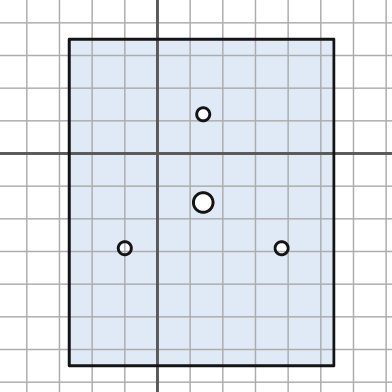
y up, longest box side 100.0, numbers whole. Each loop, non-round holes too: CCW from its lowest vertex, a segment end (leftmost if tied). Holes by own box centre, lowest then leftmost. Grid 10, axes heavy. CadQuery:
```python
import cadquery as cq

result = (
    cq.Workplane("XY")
    .moveTo(-27.0, -65.0)
    .lineTo(54.0, -65.0)
    .lineTo(54.0, 35.0)
    .lineTo(-27.0, 35.0)
    .close()
    .moveTo(-10.0, -29.0)
    .circle(2.0)
    .moveTo(38.0, -29.0)
    .circle(2.0)
    .moveTo(14.0, -15.0)
    .circle(3.0)
    .moveTo(14.0, 12.0)
    .circle(2.0)
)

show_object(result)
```